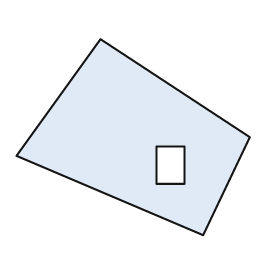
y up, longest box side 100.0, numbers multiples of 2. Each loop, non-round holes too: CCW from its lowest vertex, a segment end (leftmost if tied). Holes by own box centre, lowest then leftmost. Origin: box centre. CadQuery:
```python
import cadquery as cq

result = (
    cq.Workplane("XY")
    .moveTo(30.0, -42.0)
    .lineTo(50.0, 0.0)
    .lineTo(-14.0, 42.0)
    .lineTo(-50.0, -8.0)
    .close()
    .moveTo(10.0, -20.0)
    .lineTo(22.0, -20.0)
    .lineTo(22.0, -4.0)
    .lineTo(10.0, -4.0)
    .close()
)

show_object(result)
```